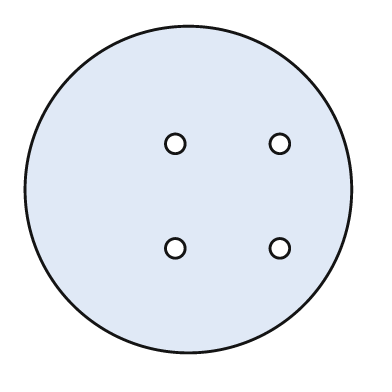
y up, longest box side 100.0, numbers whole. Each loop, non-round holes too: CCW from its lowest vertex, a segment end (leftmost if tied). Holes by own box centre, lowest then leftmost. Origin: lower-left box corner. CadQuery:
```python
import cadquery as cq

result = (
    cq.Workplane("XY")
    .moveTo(50.0, 50.0)
    .circle(50.0)
    .moveTo(46.0, 32.0)
    .circle(3.0)
    .moveTo(78.0, 32.0)
    .circle(3.0)
    .moveTo(46.0, 64.0)
    .circle(3.0)
    .moveTo(78.0, 64.0)
    .circle(3.0)
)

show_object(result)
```